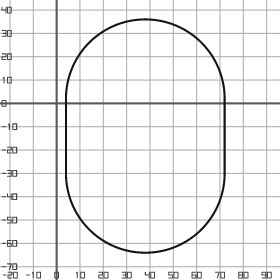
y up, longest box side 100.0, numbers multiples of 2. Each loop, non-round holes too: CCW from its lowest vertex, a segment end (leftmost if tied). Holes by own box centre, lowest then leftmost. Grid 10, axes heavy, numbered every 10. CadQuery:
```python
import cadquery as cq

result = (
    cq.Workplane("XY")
    .moveTo(4.0, -30.0)
    .threePointArc((38.0, -64.0), (72.0, -30.0))
    .lineTo(72.0, 2.0)
    .threePointArc((38.0, 36.0), (4.0, 2.0))
    .close()
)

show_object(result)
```